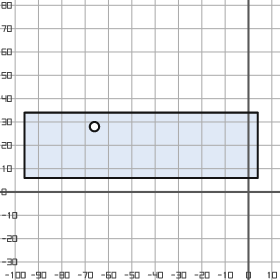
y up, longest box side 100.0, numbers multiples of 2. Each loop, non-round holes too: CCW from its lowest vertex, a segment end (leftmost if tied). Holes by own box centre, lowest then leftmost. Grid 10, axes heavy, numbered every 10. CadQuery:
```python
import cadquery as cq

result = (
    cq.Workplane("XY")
    .moveTo(-96.0, 6.0)
    .lineTo(4.0, 6.0)
    .lineTo(4.0, 34.0)
    .lineTo(-96.0, 34.0)
    .close()
    .moveTo(-66.0, 28.0)
    .circle(2.0)
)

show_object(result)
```